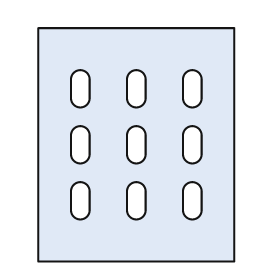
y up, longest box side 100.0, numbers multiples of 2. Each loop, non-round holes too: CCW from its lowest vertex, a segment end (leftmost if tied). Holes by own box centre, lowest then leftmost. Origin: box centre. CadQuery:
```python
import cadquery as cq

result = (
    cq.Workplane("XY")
    .moveTo(-42.0, -50.0)
    .lineTo(42.0, -50.0)
    .lineTo(42.0, 50.0)
    .lineTo(-42.0, 50.0)
    .close()
    .moveTo(-28.0, -28.0)
    .threePointArc((-24.0, -32.0), (-20.0, -28.0))
    .lineTo(-20.0, -20.0)
    .threePointArc((-24.0, -16.0), (-28.0, -20.0))
    .close()
    .moveTo(-4.0, -28.0)
    .threePointArc((0.0, -32.0), (4.0, -28.0))
    .lineTo(4.0, -20.0)
    .threePointArc((0.0, -16.0), (-4.0, -20.0))
    .close()
    .moveTo(20.0, -28.0)
    .threePointArc((24.0, -32.0), (28.0, -28.0))
    .lineTo(28.0, -20.0)
    .threePointArc((24.0, -16.0), (20.0, -20.0))
    .close()
    .moveTo(-28.0, -4.0)
    .threePointArc((-24.0, -8.0), (-20.0, -4.0))
    .lineTo(-20.0, 4.0)
    .threePointArc((-24.0, 8.0), (-28.0, 4.0))
    .close()
    .moveTo(-4.0, -4.0)
    .threePointArc((0.0, -8.0), (4.0, -4.0))
    .lineTo(4.0, 4.0)
    .threePointArc((0.0, 8.0), (-4.0, 4.0))
    .close()
    .moveTo(20.0, -4.0)
    .threePointArc((24.0, -8.0), (28.0, -4.0))
    .lineTo(28.0, 4.0)
    .threePointArc((24.0, 8.0), (20.0, 4.0))
    .close()
    .moveTo(-28.0, 20.0)
    .threePointArc((-24.0, 16.0), (-20.0, 20.0))
    .lineTo(-20.0, 28.0)
    .threePointArc((-24.0, 32.0), (-28.0, 28.0))
    .close()
    .moveTo(-4.0, 20.0)
    .threePointArc((0.0, 16.0), (4.0, 20.0))
    .lineTo(4.0, 28.0)
    .threePointArc((0.0, 32.0), (-4.0, 28.0))
    .close()
    .moveTo(20.0, 20.0)
    .threePointArc((24.0, 16.0), (28.0, 20.0))
    .lineTo(28.0, 28.0)
    .threePointArc((24.0, 32.0), (20.0, 28.0))
    .close()
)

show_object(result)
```